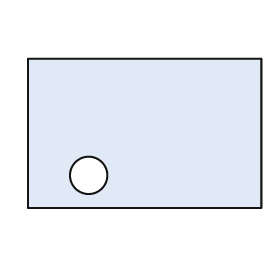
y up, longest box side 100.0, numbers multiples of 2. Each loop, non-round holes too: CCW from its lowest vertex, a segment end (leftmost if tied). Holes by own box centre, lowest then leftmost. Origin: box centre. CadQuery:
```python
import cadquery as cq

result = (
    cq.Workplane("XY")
    .moveTo(-50.0, -32.0)
    .lineTo(50.0, -32.0)
    .lineTo(50.0, 32.0)
    .lineTo(-50.0, 32.0)
    .close()
    .moveTo(-24.0, -18.0)
    .circle(8.0)
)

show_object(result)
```